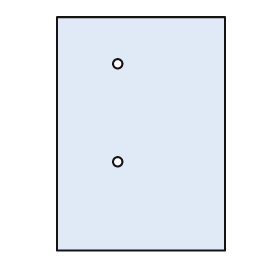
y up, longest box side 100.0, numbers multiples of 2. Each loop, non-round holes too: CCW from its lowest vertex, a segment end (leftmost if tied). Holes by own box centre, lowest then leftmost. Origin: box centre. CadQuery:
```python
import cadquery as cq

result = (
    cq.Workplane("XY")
    .moveTo(-36.0, -50.0)
    .lineTo(36.0, -50.0)
    .lineTo(36.0, 50.0)
    .lineTo(-36.0, 50.0)
    .close()
    .moveTo(-10.0, -12.0)
    .circle(2.0)
    .moveTo(-10.0, 30.0)
    .circle(2.0)
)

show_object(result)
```